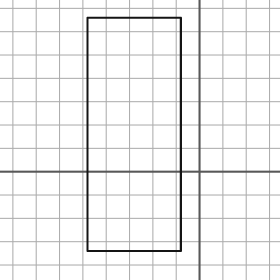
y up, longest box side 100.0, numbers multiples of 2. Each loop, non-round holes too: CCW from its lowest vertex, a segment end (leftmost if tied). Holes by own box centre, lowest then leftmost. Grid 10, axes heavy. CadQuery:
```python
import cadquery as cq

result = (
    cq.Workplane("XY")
    .moveTo(-48.0, -34.0)
    .lineTo(-8.0, -34.0)
    .lineTo(-8.0, 66.0)
    .lineTo(-48.0, 66.0)
    .close()
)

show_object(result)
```